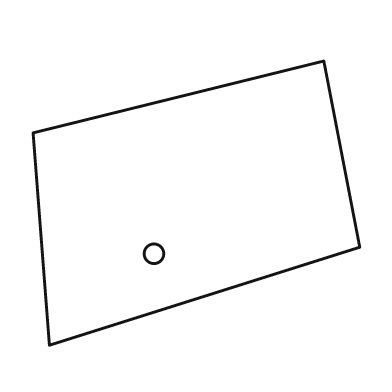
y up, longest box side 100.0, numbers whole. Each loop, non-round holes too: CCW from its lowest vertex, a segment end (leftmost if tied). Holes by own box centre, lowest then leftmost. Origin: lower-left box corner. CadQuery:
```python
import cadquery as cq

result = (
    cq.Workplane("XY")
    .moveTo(5.0, 0.0)
    .lineTo(100.0, 30.0)
    .lineTo(89.0, 87.0)
    .lineTo(0.0, 65.0)
    .close()
    .moveTo(37.0, 28.0)
    .circle(3.0)
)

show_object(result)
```